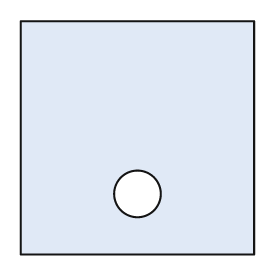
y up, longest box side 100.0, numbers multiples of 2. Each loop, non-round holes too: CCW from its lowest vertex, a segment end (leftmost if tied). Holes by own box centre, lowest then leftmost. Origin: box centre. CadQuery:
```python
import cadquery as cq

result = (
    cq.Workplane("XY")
    .moveTo(-50.0, -50.0)
    .lineTo(50.0, -50.0)
    .lineTo(50.0, 50.0)
    .lineTo(-50.0, 50.0)
    .close()
    .moveTo(0.0, -24.0)
    .circle(10.0)
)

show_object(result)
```